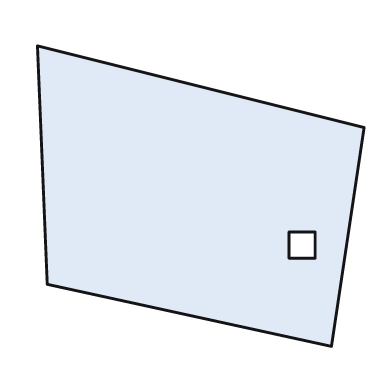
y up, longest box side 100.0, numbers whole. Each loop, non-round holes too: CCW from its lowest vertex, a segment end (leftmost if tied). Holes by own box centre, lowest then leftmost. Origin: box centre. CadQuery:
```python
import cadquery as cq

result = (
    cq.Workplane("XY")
    .moveTo(40.0, -46.0)
    .lineTo(50.0, 21.0)
    .lineTo(-50.0, 46.0)
    .lineTo(-47.0, -27.0)
    .close()
    .moveTo(27.0, -19.0)
    .lineTo(35.0, -19.0)
    .lineTo(35.0, -11.0)
    .lineTo(27.0, -11.0)
    .close()
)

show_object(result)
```